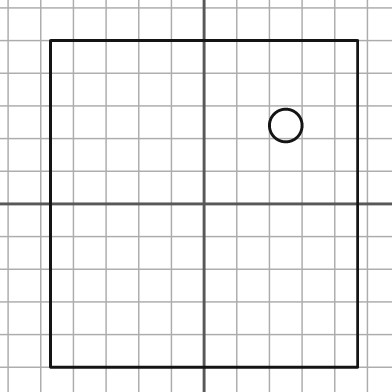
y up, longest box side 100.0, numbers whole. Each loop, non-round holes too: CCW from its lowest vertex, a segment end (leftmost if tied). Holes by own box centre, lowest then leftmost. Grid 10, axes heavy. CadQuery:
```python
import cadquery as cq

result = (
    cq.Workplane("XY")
    .moveTo(-47.0, -50.0)
    .lineTo(47.0, -50.0)
    .lineTo(47.0, 50.0)
    .lineTo(-47.0, 50.0)
    .close()
    .moveTo(25.0, 24.0)
    .circle(5.0)
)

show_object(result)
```